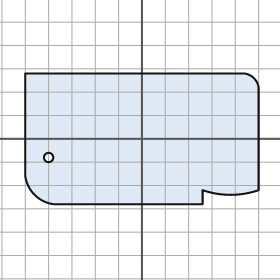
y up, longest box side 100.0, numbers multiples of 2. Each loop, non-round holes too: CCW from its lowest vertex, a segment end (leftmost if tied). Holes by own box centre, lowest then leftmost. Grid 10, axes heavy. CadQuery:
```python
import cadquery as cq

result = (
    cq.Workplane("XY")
    .moveTo(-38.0, -28.0)
    .lineTo(26.0, -28.0)
    .lineTo(26.0, -22.0)
    .threePointArc((38.0, -24.0), (50.0, -22.0))
    .lineTo(50.0, 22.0)
    .threePointArc((48.0, 26.0), (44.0, 28.0))
    .lineTo(-50.0, 28.0)
    .lineTo(-50.0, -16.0)
    .threePointArc((-46.0, -24.0), (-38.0, -28.0))
    .close()
    .moveTo(-40.0, -8.0)
    .circle(2.0)
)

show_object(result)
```